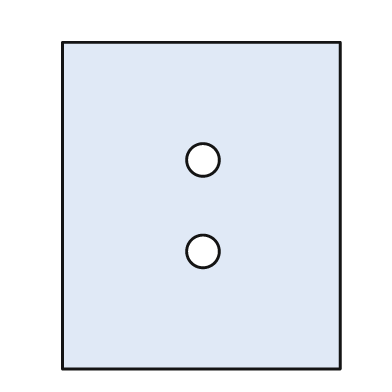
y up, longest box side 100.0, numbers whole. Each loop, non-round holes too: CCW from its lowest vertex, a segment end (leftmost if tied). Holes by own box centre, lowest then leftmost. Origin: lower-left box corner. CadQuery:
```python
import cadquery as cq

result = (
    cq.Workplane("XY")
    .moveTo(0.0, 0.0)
    .lineTo(85.0, 0.0)
    .lineTo(85.0, 100.0)
    .lineTo(0.0, 100.0)
    .close()
    .moveTo(43.0, 36.0)
    .circle(5.0)
    .moveTo(43.0, 64.0)
    .circle(5.0)
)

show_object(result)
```